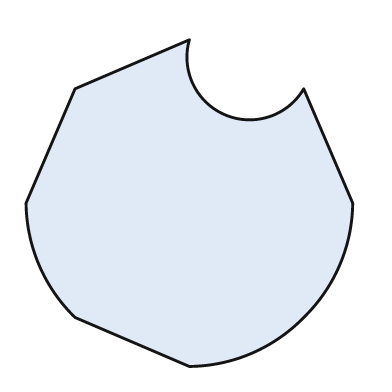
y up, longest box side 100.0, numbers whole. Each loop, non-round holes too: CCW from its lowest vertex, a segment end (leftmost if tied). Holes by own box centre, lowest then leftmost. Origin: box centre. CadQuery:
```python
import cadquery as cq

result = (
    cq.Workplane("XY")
    .moveTo(0.0, -50.0)
    .threePointArc((19.0, -46.0), (35.0, -35.0))
    .threePointArc((46.0, -19.0), (50.0, 0.0))
    .lineTo(35.0, 35.0)
    .threePointArc((11.0, 27.0), (0.0, 50.0))
    .lineTo(-35.0, 35.0)
    .lineTo(-50.0, 0.0)
    .threePointArc((-46.0, -19.0), (-35.0, -35.0))
    .close()
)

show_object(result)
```